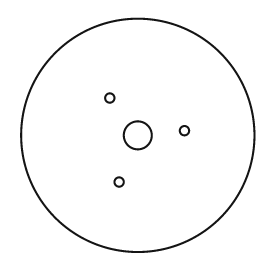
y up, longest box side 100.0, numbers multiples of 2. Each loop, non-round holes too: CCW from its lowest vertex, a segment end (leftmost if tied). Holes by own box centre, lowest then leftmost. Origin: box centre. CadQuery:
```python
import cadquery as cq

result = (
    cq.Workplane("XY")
    .moveTo(0.0, 0.0)
    .circle(50.0)
    .moveTo(-8.0, -20.0)
    .circle(2.0)
    .moveTo(0.0, 0.0)
    .circle(6.0)
    .moveTo(20.0, 2.0)
    .circle(2.0)
    .moveTo(-12.0, 16.0)
    .circle(2.0)
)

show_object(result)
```